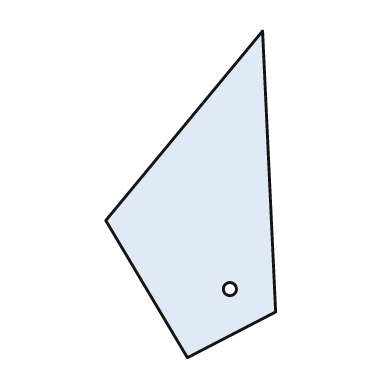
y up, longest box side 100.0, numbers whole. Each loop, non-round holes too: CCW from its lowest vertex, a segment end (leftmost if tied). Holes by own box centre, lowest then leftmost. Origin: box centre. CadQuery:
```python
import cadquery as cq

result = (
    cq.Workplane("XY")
    .moveTo(-1.0, -50.0)
    .lineTo(26.0, -36.0)
    .lineTo(22.0, 50.0)
    .lineTo(-26.0, -8.0)
    .close()
    .moveTo(12.0, -29.0)
    .circle(2.0)
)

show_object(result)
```